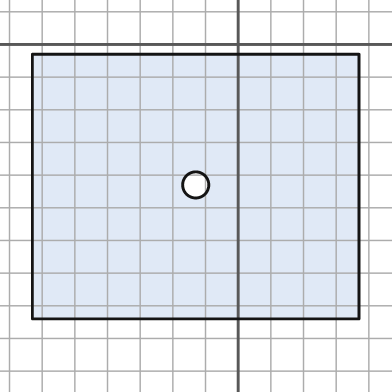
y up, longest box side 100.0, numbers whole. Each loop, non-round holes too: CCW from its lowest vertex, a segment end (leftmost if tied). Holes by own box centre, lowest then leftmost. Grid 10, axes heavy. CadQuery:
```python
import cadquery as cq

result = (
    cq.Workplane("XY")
    .moveTo(-63.0, -84.0)
    .lineTo(37.0, -84.0)
    .lineTo(37.0, -3.0)
    .lineTo(-63.0, -3.0)
    .close()
    .moveTo(-13.0, -43.0)
    .circle(4.0)
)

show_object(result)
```